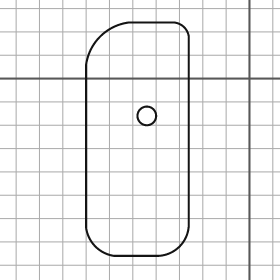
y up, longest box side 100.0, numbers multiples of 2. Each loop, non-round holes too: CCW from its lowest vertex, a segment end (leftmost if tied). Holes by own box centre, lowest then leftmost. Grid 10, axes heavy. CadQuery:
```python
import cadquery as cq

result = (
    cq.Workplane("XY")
    .moveTo(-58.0, -76.0)
    .lineTo(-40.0, -76.0)
    .threePointArc((-30.0, -72.0), (-26.0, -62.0))
    .lineTo(-26.0, 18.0)
    .threePointArc((-28.0, 22.0), (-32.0, 24.0))
    .lineTo(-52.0, 24.0)
    .threePointArc((-64.0, 18.0), (-70.0, 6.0))
    .lineTo(-70.0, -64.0)
    .threePointArc((-66.0, -72.0), (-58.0, -76.0))
    .close()
    .moveTo(-44.0, -16.0)
    .circle(4.0)
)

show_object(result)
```